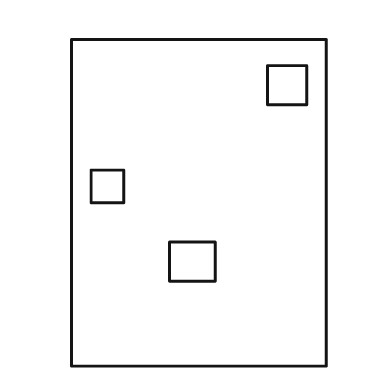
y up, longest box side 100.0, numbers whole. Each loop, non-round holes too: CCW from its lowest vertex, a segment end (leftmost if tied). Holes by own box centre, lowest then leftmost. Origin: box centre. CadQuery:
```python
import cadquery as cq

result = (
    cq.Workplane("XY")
    .moveTo(-39.0, -50.0)
    .lineTo(39.0, -50.0)
    .lineTo(39.0, 50.0)
    .lineTo(-39.0, 50.0)
    .close()
    .moveTo(-9.0, -24.0)
    .lineTo(5.0, -24.0)
    .lineTo(5.0, -12.0)
    .lineTo(-9.0, -12.0)
    .close()
    .moveTo(-33.0, 0.0)
    .lineTo(-23.0, 0.0)
    .lineTo(-23.0, 10.0)
    .lineTo(-33.0, 10.0)
    .close()
    .moveTo(21.0, 30.0)
    .lineTo(33.0, 30.0)
    .lineTo(33.0, 42.0)
    .lineTo(21.0, 42.0)
    .close()
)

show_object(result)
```